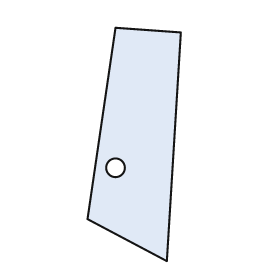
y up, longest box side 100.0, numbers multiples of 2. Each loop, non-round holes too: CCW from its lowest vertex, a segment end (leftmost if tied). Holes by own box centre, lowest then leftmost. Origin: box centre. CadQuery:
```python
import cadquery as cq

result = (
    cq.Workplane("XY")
    .moveTo(14.0, -50.0)
    .lineTo(20.0, 48.0)
    .lineTo(-8.0, 50.0)
    .lineTo(-20.0, -32.0)
    .close()
    .moveTo(-8.0, -10.0)
    .circle(4.0)
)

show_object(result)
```